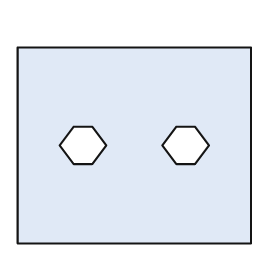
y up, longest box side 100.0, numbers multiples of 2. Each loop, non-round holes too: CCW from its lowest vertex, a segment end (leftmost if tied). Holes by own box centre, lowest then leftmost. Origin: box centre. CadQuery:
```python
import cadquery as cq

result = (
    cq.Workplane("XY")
    .moveTo(-50.0, -42.0)
    .lineTo(50.0, -42.0)
    .lineTo(50.0, 42.0)
    .lineTo(-50.0, 42.0)
    .close()
    .moveTo(-26.0, -8.0)
    .lineTo(-18.0, -8.0)
    .lineTo(-12.0, 0.0)
    .lineTo(-18.0, 8.0)
    .lineTo(-26.0, 8.0)
    .lineTo(-32.0, 0.0)
    .close()
    .moveTo(18.0, -8.0)
    .lineTo(26.0, -8.0)
    .lineTo(32.0, 0.0)
    .lineTo(26.0, 8.0)
    .lineTo(18.0, 8.0)
    .lineTo(12.0, 0.0)
    .close()
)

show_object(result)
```